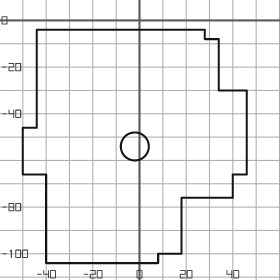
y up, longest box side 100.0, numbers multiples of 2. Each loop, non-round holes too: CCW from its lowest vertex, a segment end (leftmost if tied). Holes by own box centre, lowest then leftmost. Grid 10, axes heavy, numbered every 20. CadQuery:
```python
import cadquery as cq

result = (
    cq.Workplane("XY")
    .moveTo(-40.0, -104.0)
    .lineTo(8.0, -104.0)
    .lineTo(8.0, -100.0)
    .lineTo(18.0, -100.0)
    .lineTo(18.0, -76.0)
    .lineTo(40.0, -76.0)
    .lineTo(40.0, -66.0)
    .lineTo(46.0, -66.0)
    .lineTo(46.0, -30.0)
    .lineTo(34.0, -30.0)
    .lineTo(34.0, -8.0)
    .lineTo(28.0, -8.0)
    .lineTo(28.0, -4.0)
    .lineTo(-44.0, -4.0)
    .lineTo(-44.0, -46.0)
    .lineTo(-50.0, -46.0)
    .lineTo(-50.0, -66.0)
    .lineTo(-40.0, -66.0)
    .close()
    .moveTo(-2.0, -54.0)
    .circle(6.0)
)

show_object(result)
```